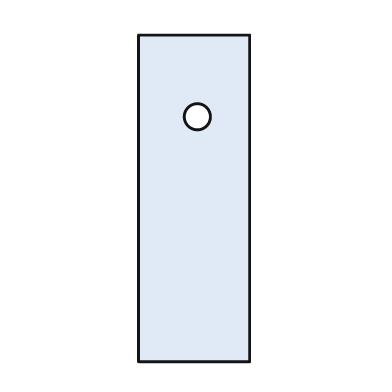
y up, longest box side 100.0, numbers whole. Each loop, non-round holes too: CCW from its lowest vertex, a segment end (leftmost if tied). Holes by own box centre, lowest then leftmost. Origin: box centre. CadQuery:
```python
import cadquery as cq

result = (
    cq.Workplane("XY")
    .moveTo(-17.0, -50.0)
    .lineTo(17.0, -50.0)
    .lineTo(17.0, 50.0)
    .lineTo(-17.0, 50.0)
    .close()
    .moveTo(1.0, 25.0)
    .circle(4.0)
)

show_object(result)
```